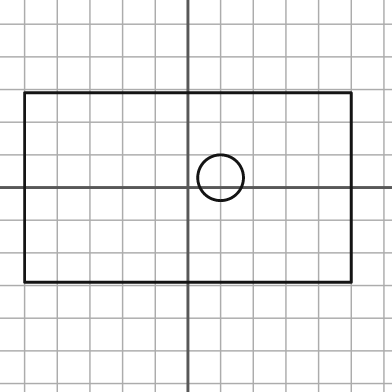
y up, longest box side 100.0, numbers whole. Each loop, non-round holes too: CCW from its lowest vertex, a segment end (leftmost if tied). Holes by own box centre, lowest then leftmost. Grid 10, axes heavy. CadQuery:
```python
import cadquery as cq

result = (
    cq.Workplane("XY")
    .moveTo(-50.0, -29.0)
    .lineTo(50.0, -29.0)
    .lineTo(50.0, 29.0)
    .lineTo(-50.0, 29.0)
    .close()
    .moveTo(10.0, 3.0)
    .circle(7.0)
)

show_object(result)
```